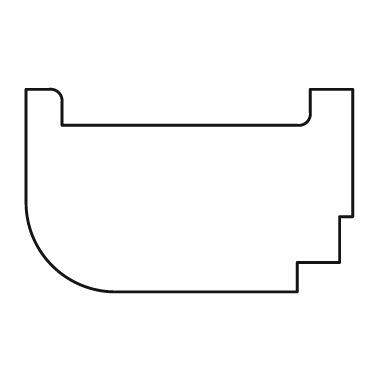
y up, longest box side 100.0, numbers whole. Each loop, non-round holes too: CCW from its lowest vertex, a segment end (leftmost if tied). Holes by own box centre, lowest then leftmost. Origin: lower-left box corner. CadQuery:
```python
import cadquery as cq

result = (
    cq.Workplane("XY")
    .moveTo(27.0, 0.0)
    .lineTo(83.0, 0.0)
    .lineTo(83.0, 9.0)
    .lineTo(96.0, 9.0)
    .lineTo(96.0, 23.0)
    .lineTo(100.0, 23.0)
    .lineTo(100.0, 62.0)
    .lineTo(87.0, 62.0)
    .lineTo(87.0, 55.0)
    .threePointArc((86.0, 52.0), (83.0, 51.0))
    .lineTo(11.0, 51.0)
    .lineTo(11.0, 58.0)
    .threePointArc((10.0, 61.0), (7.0, 62.0))
    .lineTo(0.0, 62.0)
    .lineTo(0.0, 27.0)
    .threePointArc((8.0, 8.0), (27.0, 0.0))
    .close()
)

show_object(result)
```